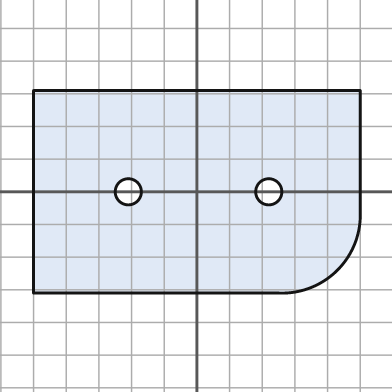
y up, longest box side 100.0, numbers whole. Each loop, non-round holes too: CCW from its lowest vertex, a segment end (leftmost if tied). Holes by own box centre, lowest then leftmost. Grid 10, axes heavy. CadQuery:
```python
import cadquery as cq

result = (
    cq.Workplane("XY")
    .moveTo(-50.0, -31.0)
    .lineTo(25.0, -31.0)
    .threePointArc((43.0, -24.0), (50.0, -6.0))
    .lineTo(50.0, 31.0)
    .lineTo(-50.0, 31.0)
    .close()
    .moveTo(-21.0, 0.0)
    .circle(4.0)
    .moveTo(22.0, 0.0)
    .circle(4.0)
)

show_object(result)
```